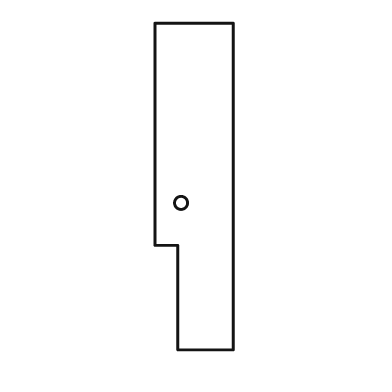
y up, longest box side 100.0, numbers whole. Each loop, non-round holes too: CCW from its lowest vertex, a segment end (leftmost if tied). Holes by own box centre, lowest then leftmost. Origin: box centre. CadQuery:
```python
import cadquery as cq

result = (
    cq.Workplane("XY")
    .moveTo(-5.0, -50.0)
    .lineTo(12.0, -50.0)
    .lineTo(12.0, 50.0)
    .lineTo(-12.0, 50.0)
    .lineTo(-12.0, -18.0)
    .lineTo(-5.0, -18.0)
    .close()
    .moveTo(-4.0, -5.0)
    .circle(2.0)
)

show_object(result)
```